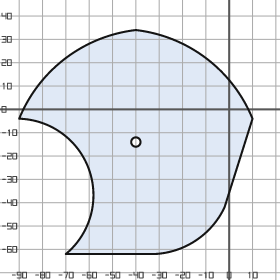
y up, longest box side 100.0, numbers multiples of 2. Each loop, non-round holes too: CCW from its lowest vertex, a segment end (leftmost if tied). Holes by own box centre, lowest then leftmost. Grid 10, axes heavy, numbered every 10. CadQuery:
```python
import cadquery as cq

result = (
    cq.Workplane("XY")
    .moveTo(-70.0, -62.0)
    .lineTo(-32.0, -62.0)
    .threePointArc((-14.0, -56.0), (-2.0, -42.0))
    .lineTo(10.0, -4.0)
    .threePointArc((-10.0, 22.0), (-40.0, 34.0))
    .threePointArc((-70.0, 22.0), (-90.0, -4.0))
    .threePointArc((-60.0, -26.0), (-70.0, -62.0))
    .close()
    .moveTo(-40.0, -14.0)
    .circle(2.0)
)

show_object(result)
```